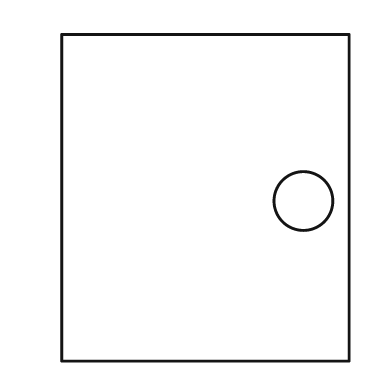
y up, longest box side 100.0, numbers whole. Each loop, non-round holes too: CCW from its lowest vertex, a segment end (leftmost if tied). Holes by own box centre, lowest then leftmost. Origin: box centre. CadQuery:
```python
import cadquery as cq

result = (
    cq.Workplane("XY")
    .moveTo(-44.0, -50.0)
    .lineTo(44.0, -50.0)
    .lineTo(44.0, 50.0)
    .lineTo(-44.0, 50.0)
    .close()
    .moveTo(30.0, -1.0)
    .circle(9.0)
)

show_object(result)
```